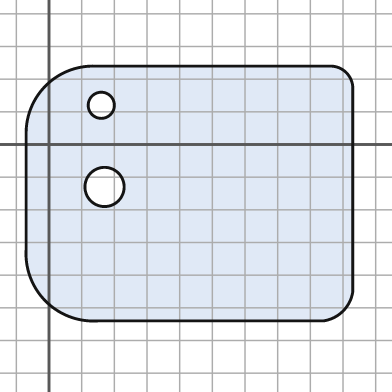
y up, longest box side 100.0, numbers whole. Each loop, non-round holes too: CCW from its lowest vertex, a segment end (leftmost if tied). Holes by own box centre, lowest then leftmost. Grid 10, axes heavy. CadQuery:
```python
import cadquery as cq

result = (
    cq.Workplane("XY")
    .moveTo(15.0, -54.0)
    .lineTo(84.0, -54.0)
    .threePointArc((90.0, -51.0), (93.0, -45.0))
    .lineTo(93.0, 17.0)
    .threePointArc((91.0, 22.0), (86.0, 24.0))
    .lineTo(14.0, 24.0)
    .threePointArc((-1.0, 18.0), (-7.0, 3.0))
    .lineTo(-7.0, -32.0)
    .threePointArc((-1.0, -48.0), (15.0, -54.0))
    .close()
    .moveTo(17.0, -13.0)
    .circle(6.0)
    .moveTo(16.0, 12.0)
    .circle(4.0)
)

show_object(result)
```